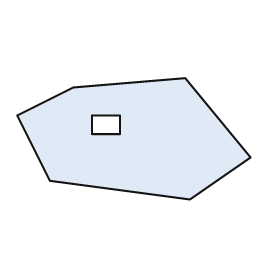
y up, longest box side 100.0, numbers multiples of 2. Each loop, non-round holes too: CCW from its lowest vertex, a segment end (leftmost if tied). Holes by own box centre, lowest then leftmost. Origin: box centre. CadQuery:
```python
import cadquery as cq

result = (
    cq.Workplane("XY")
    .moveTo(24.0, -26.0)
    .lineTo(50.0, -8.0)
    .lineTo(22.0, 26.0)
    .lineTo(-26.0, 22.0)
    .lineTo(-50.0, 10.0)
    .lineTo(-36.0, -18.0)
    .close()
    .moveTo(-18.0, 2.0)
    .lineTo(-6.0, 2.0)
    .lineTo(-6.0, 10.0)
    .lineTo(-18.0, 10.0)
    .close()
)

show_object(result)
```